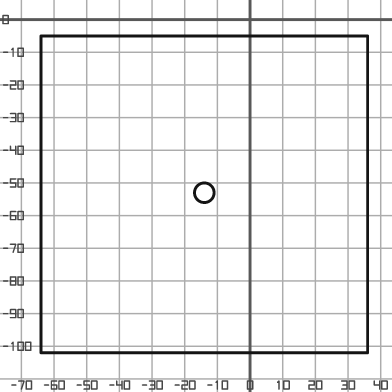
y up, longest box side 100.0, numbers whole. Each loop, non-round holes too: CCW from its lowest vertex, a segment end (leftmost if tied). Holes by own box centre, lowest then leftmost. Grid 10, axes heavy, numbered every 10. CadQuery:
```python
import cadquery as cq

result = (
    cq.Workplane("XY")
    .moveTo(-64.0, -102.0)
    .lineTo(36.0, -102.0)
    .lineTo(36.0, -5.0)
    .lineTo(-64.0, -5.0)
    .close()
    .moveTo(-14.0, -53.0)
    .circle(3.0)
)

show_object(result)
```